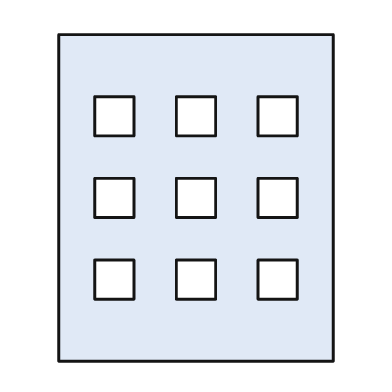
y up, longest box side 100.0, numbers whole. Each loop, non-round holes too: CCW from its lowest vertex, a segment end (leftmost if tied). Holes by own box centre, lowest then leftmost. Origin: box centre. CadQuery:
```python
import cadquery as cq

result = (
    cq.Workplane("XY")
    .moveTo(-42.0, -50.0)
    .lineTo(42.0, -50.0)
    .lineTo(42.0, 50.0)
    .lineTo(-42.0, 50.0)
    .close()
    .moveTo(-31.0, -31.0)
    .lineTo(-19.0, -31.0)
    .lineTo(-19.0, -19.0)
    .lineTo(-31.0, -19.0)
    .close()
    .moveTo(-6.0, -31.0)
    .lineTo(6.0, -31.0)
    .lineTo(6.0, -19.0)
    .lineTo(-6.0, -19.0)
    .close()
    .moveTo(19.0, -31.0)
    .lineTo(31.0, -31.0)
    .lineTo(31.0, -19.0)
    .lineTo(19.0, -19.0)
    .close()
    .moveTo(-31.0, -6.0)
    .lineTo(-19.0, -6.0)
    .lineTo(-19.0, 6.0)
    .lineTo(-31.0, 6.0)
    .close()
    .moveTo(-6.0, -6.0)
    .lineTo(6.0, -6.0)
    .lineTo(6.0, 6.0)
    .lineTo(-6.0, 6.0)
    .close()
    .moveTo(19.0, -6.0)
    .lineTo(31.0, -6.0)
    .lineTo(31.0, 6.0)
    .lineTo(19.0, 6.0)
    .close()
    .moveTo(-31.0, 19.0)
    .lineTo(-19.0, 19.0)
    .lineTo(-19.0, 31.0)
    .lineTo(-31.0, 31.0)
    .close()
    .moveTo(-6.0, 19.0)
    .lineTo(6.0, 19.0)
    .lineTo(6.0, 31.0)
    .lineTo(-6.0, 31.0)
    .close()
    .moveTo(19.0, 19.0)
    .lineTo(31.0, 19.0)
    .lineTo(31.0, 31.0)
    .lineTo(19.0, 31.0)
    .close()
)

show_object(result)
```